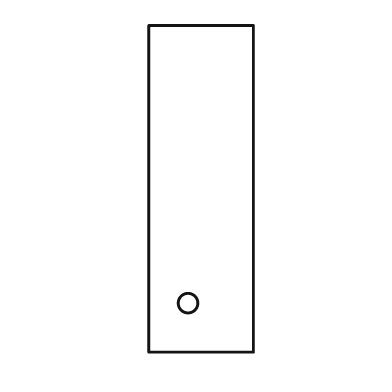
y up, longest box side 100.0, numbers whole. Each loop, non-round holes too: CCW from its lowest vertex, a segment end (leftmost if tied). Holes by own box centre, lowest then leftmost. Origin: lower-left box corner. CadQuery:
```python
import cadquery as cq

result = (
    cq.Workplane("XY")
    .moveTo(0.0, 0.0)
    .lineTo(32.0, 0.0)
    .lineTo(32.0, 100.0)
    .lineTo(0.0, 100.0)
    .close()
    .moveTo(12.0, 15.0)
    .circle(3.0)
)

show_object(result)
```